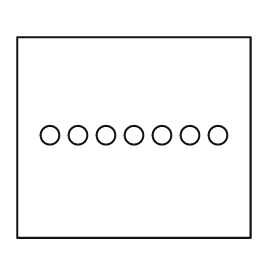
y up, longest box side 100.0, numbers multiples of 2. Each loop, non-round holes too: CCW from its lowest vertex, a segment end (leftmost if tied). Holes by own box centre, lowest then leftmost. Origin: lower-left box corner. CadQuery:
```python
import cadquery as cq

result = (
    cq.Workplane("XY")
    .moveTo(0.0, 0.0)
    .lineTo(100.0, 0.0)
    .lineTo(100.0, 86.0)
    .lineTo(0.0, 86.0)
    .close()
    .moveTo(14.0, 44.0)
    .circle(4.0)
    .moveTo(26.0, 44.0)
    .circle(4.0)
    .moveTo(38.0, 44.0)
    .circle(4.0)
    .moveTo(50.0, 44.0)
    .circle(4.0)
    .moveTo(62.0, 44.0)
    .circle(4.0)
    .moveTo(74.0, 44.0)
    .circle(4.0)
    .moveTo(86.0, 44.0)
    .circle(4.0)
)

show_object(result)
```